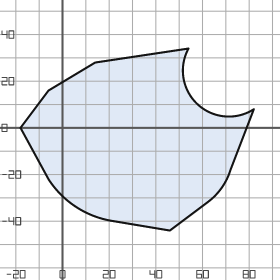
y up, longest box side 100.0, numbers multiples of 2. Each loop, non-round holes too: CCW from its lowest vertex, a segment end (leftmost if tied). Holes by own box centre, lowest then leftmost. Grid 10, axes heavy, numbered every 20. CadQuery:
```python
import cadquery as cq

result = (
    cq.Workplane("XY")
    .moveTo(46.0, -44.0)
    .lineTo(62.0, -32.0)
    .threePointArc((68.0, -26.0), (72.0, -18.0))
    .lineTo(82.0, 8.0)
    .threePointArc((58.0, 10.0), (54.0, 34.0))
    .lineTo(14.0, 28.0)
    .lineTo(-6.0, 16.0)
    .lineTo(-18.0, 0.0)
    .lineTo(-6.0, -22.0)
    .threePointArc((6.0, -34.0), (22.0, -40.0))
    .close()
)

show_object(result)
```